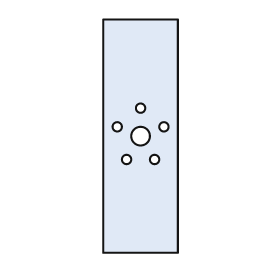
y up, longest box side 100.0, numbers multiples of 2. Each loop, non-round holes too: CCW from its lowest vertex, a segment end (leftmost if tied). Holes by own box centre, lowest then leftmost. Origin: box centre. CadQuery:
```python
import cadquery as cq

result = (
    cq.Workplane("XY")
    .moveTo(-16.0, -50.0)
    .lineTo(16.0, -50.0)
    .lineTo(16.0, 50.0)
    .lineTo(-16.0, 50.0)
    .close()
    .moveTo(-6.0, -10.0)
    .circle(2.0)
    .moveTo(6.0, -10.0)
    .circle(2.0)
    .moveTo(0.0, 0.0)
    .circle(4.0)
    .moveTo(-10.0, 4.0)
    .circle(2.0)
    .moveTo(10.0, 4.0)
    .circle(2.0)
    .moveTo(0.0, 12.0)
    .circle(2.0)
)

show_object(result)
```